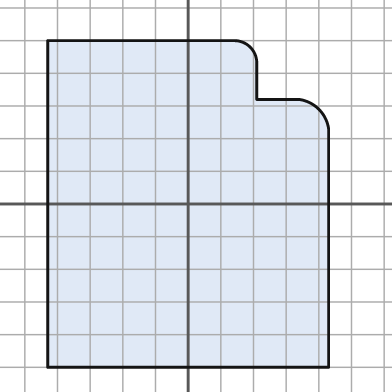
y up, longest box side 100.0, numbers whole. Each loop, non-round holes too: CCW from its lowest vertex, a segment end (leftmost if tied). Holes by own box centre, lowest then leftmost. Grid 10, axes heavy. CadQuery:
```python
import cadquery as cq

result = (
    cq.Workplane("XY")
    .moveTo(-43.0, -50.0)
    .lineTo(43.0, -50.0)
    .lineTo(43.0, 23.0)
    .threePointArc((40.0, 29.0), (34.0, 32.0))
    .lineTo(21.0, 32.0)
    .lineTo(21.0, 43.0)
    .threePointArc((19.0, 48.0), (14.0, 50.0))
    .lineTo(-43.0, 50.0)
    .close()
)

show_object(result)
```